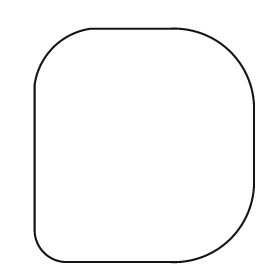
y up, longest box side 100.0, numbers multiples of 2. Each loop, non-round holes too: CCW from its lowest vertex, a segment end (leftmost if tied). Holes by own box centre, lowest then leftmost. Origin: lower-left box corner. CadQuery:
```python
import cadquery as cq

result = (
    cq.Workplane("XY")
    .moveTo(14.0, 0.0)
    .lineTo(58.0, 0.0)
    .threePointArc((84.0, 10.0), (94.0, 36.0))
    .lineTo(94.0, 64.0)
    .threePointArc((84.0, 90.0), (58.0, 100.0))
    .lineTo(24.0, 100.0)
    .threePointArc((8.0, 92.0), (0.0, 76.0))
    .lineTo(0.0, 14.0)
    .threePointArc((4.0, 4.0), (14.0, 0.0))
    .close()
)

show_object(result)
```